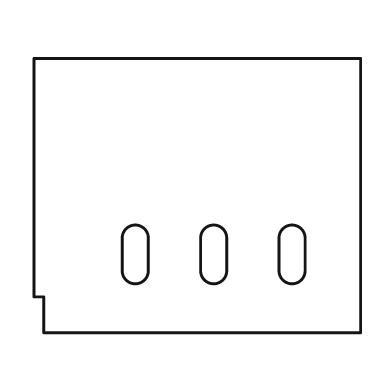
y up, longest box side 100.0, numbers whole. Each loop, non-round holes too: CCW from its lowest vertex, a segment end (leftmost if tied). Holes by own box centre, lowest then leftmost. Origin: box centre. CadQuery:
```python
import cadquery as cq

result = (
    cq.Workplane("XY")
    .moveTo(-47.0, -42.0)
    .lineTo(50.0, -42.0)
    .lineTo(50.0, 42.0)
    .lineTo(-50.0, 42.0)
    .lineTo(-50.0, -31.0)
    .lineTo(-47.0, -31.0)
    .close()
    .moveTo(-23.0, -23.0)
    .threePointArc((-19.0, -27.0), (-15.0, -23.0))
    .lineTo(-15.0, -13.0)
    .threePointArc((-19.0, -9.0), (-23.0, -13.0))
    .close()
    .moveTo(1.0, -23.0)
    .threePointArc((5.0, -27.0), (9.0, -23.0))
    .lineTo(9.0, -13.0)
    .threePointArc((5.0, -9.0), (1.0, -13.0))
    .close()
    .moveTo(25.0, -23.0)
    .threePointArc((29.0, -27.0), (33.0, -23.0))
    .lineTo(33.0, -13.0)
    .threePointArc((29.0, -9.0), (25.0, -13.0))
    .close()
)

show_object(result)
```